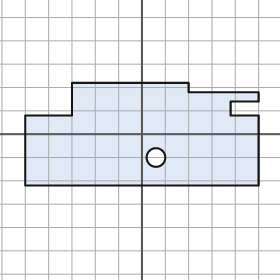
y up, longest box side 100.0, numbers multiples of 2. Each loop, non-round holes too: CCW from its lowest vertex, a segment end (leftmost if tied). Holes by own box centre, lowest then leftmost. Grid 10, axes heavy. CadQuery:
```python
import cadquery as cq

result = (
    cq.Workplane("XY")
    .moveTo(-50.0, -22.0)
    .lineTo(50.0, -22.0)
    .lineTo(50.0, 8.0)
    .lineTo(38.0, 8.0)
    .lineTo(38.0, 14.0)
    .lineTo(50.0, 14.0)
    .lineTo(50.0, 18.0)
    .lineTo(20.0, 18.0)
    .lineTo(20.0, 22.0)
    .lineTo(-30.0, 22.0)
    .lineTo(-30.0, 8.0)
    .lineTo(-50.0, 8.0)
    .close()
    .moveTo(6.0, -10.0)
    .circle(4.0)
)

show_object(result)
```